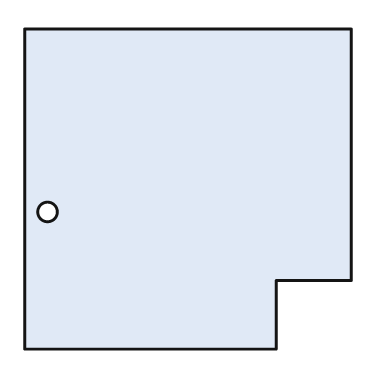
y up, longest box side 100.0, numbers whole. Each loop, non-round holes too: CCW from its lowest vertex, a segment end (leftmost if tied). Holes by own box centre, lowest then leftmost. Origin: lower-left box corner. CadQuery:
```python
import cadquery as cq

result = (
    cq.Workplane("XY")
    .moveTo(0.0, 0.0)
    .lineTo(77.0, 0.0)
    .lineTo(77.0, 21.0)
    .lineTo(100.0, 21.0)
    .lineTo(100.0, 98.0)
    .lineTo(0.0, 98.0)
    .close()
    .moveTo(7.0, 42.0)
    .circle(3.0)
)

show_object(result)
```